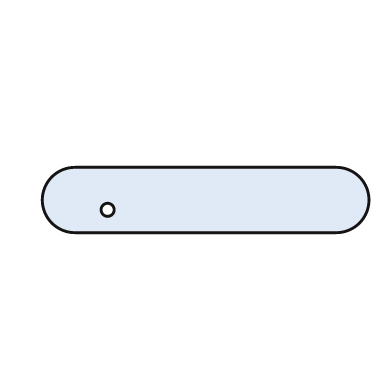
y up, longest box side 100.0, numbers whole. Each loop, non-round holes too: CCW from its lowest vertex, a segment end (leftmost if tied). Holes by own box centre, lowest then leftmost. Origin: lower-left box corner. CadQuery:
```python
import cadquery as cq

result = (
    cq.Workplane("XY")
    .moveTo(10.0, 0.0)
    .lineTo(90.0, 0.0)
    .threePointArc((100.0, 10.0), (90.0, 20.0))
    .lineTo(10.0, 20.0)
    .threePointArc((0.0, 10.0), (10.0, 0.0))
    .close()
    .moveTo(20.0, 7.0)
    .circle(2.0)
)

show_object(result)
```